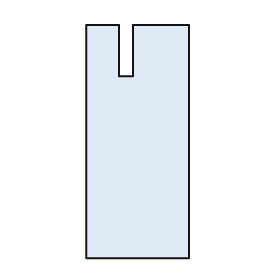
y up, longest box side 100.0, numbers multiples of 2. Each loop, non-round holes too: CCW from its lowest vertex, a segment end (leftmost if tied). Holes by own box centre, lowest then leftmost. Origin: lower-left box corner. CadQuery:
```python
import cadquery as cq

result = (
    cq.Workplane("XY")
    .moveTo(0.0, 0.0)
    .lineTo(44.0, 0.0)
    .lineTo(44.0, 100.0)
    .lineTo(20.0, 100.0)
    .lineTo(20.0, 78.0)
    .lineTo(14.0, 78.0)
    .lineTo(14.0, 100.0)
    .lineTo(0.0, 100.0)
    .close()
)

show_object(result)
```